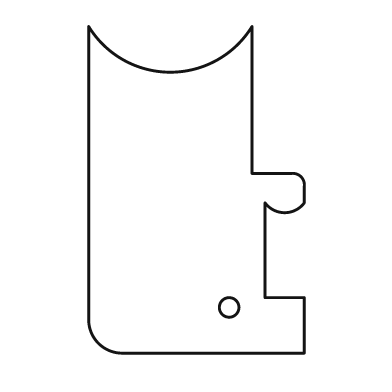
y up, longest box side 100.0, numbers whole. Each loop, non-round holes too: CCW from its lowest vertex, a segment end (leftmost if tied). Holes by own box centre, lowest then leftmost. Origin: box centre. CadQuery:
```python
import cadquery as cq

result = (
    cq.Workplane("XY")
    .moveTo(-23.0, -50.0)
    .lineTo(33.0, -50.0)
    .lineTo(33.0, -33.0)
    .lineTo(21.0, -33.0)
    .lineTo(21.0, -4.0)
    .threePointArc((27.0, -7.0), (33.0, -4.0))
    .lineTo(33.0, 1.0)
    .threePointArc((32.0, 4.0), (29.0, 5.0))
    .lineTo(17.0, 5.0)
    .lineTo(17.0, 50.0)
    .threePointArc((-8.0, 36.0), (-33.0, 50.0))
    .lineTo(-33.0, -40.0)
    .threePointArc((-30.0, -47.0), (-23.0, -50.0))
    .close()
    .moveTo(10.0, -36.0)
    .circle(3.0)
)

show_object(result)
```